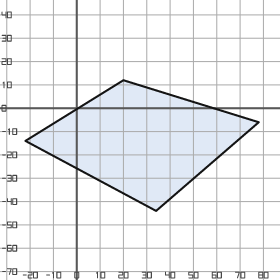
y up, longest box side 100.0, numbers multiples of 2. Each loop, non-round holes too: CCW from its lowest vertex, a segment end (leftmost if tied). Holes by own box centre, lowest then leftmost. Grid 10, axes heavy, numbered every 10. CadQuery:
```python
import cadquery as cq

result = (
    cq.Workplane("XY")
    .moveTo(34.0, -44.0)
    .lineTo(78.0, -6.0)
    .lineTo(20.0, 12.0)
    .lineTo(-22.0, -14.0)
    .close()
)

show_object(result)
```